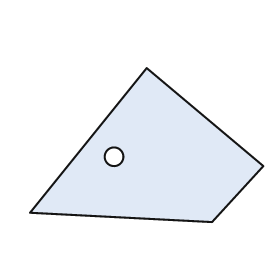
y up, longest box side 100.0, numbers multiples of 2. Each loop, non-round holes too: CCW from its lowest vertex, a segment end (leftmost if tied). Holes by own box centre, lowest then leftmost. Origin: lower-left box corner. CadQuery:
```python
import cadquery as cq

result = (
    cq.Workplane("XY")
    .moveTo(78.0, 0.0)
    .lineTo(100.0, 24.0)
    .lineTo(50.0, 66.0)
    .lineTo(0.0, 4.0)
    .close()
    .moveTo(36.0, 28.0)
    .circle(4.0)
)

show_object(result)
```